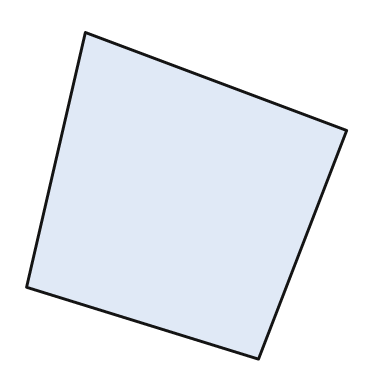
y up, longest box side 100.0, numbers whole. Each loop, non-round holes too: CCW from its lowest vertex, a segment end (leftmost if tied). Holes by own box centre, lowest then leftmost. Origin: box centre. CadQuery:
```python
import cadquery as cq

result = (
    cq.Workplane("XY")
    .moveTo(22.0, -50.0)
    .lineTo(49.0, 20.0)
    .lineTo(-31.0, 50.0)
    .lineTo(-49.0, -28.0)
    .close()
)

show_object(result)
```